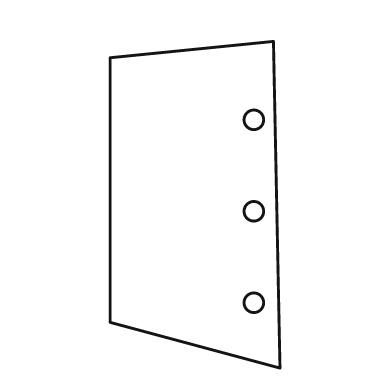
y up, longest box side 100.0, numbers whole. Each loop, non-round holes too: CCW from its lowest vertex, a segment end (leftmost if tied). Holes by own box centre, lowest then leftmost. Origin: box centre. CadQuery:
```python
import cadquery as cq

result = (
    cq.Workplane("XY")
    .moveTo(26.0, -50.0)
    .lineTo(24.0, 50.0)
    .lineTo(-26.0, 45.0)
    .lineTo(-26.0, -36.0)
    .close()
    .moveTo(18.0, -30.0)
    .circle(3.0)
    .moveTo(18.0, -2.0)
    .circle(3.0)
    .moveTo(18.0, 26.0)
    .circle(3.0)
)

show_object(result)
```